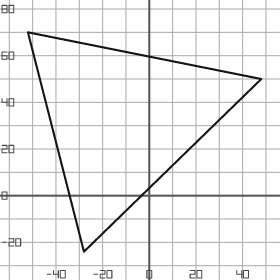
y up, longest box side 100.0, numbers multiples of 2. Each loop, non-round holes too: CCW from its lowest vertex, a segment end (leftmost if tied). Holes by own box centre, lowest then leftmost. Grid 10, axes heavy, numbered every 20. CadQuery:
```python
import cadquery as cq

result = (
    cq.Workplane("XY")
    .moveTo(-28.0, -24.0)
    .lineTo(48.0, 50.0)
    .lineTo(-52.0, 70.0)
    .close()
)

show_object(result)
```